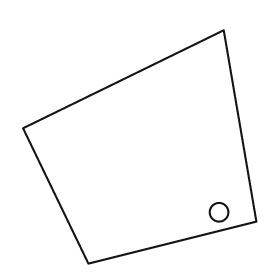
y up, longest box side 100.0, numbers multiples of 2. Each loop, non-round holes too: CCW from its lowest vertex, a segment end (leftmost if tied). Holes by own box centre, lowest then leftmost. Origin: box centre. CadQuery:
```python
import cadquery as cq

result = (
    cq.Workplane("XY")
    .moveTo(-22.0, -50.0)
    .lineTo(50.0, -32.0)
    .lineTo(36.0, 50.0)
    .lineTo(-50.0, 8.0)
    .close()
    .moveTo(34.0, -28.0)
    .circle(4.0)
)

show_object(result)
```